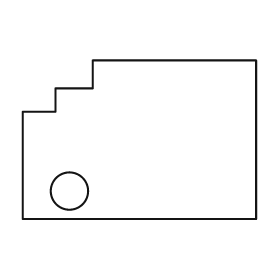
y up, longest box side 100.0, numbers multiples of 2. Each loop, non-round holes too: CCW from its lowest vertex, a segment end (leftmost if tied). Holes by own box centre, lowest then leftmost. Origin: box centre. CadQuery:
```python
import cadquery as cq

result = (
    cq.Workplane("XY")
    .moveTo(-50.0, -34.0)
    .lineTo(50.0, -34.0)
    .lineTo(50.0, 34.0)
    .lineTo(-20.0, 34.0)
    .lineTo(-20.0, 22.0)
    .lineTo(-36.0, 22.0)
    .lineTo(-36.0, 12.0)
    .lineTo(-50.0, 12.0)
    .close()
    .moveTo(-30.0, -22.0)
    .circle(8.0)
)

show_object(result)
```